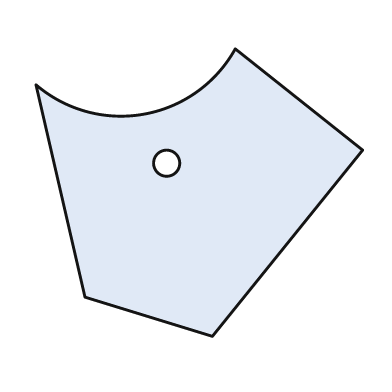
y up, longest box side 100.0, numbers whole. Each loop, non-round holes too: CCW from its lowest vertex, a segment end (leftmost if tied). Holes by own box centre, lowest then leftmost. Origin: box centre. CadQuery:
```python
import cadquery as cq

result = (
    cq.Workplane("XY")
    .moveTo(4.0, -44.0)
    .lineTo(50.0, 13.0)
    .lineTo(11.0, 44.0)
    .threePointArc((-17.0, 24.0), (-50.0, 33.0))
    .lineTo(-35.0, -32.0)
    .close()
    .moveTo(-10.0, 9.0)
    .circle(4.0)
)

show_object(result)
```